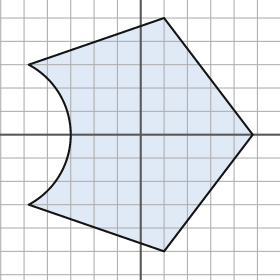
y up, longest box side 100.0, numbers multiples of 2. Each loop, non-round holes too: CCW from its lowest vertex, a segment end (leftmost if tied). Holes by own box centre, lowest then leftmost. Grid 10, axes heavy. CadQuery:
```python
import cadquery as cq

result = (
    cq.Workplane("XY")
    .moveTo(10.0, -50.0)
    .lineTo(48.0, 0.0)
    .lineTo(10.0, 50.0)
    .lineTo(-48.0, 30.0)
    .threePointArc((-30.0, 0.0), (-48.0, -30.0))
    .close()
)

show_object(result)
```